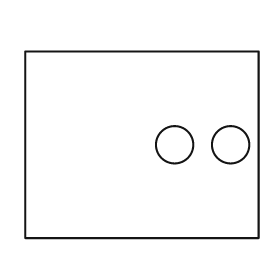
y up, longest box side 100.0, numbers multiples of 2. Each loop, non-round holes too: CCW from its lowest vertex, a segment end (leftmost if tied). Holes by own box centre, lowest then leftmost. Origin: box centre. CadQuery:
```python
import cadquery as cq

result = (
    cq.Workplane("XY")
    .moveTo(-50.0, -40.0)
    .lineTo(50.0, -40.0)
    .lineTo(50.0, 40.0)
    .lineTo(-50.0, 40.0)
    .close()
    .moveTo(14.0, 0.0)
    .circle(8.0)
    .moveTo(38.0, 0.0)
    .circle(8.0)
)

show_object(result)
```